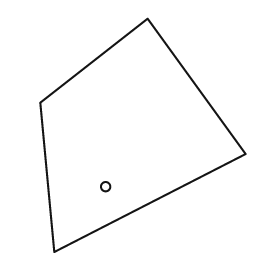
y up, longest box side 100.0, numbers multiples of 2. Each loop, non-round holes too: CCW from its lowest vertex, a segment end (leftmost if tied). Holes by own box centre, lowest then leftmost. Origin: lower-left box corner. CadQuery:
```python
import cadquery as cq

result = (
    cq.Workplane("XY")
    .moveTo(6.0, 0.0)
    .lineTo(88.0, 42.0)
    .lineTo(46.0, 100.0)
    .lineTo(0.0, 64.0)
    .close()
    .moveTo(28.0, 28.0)
    .circle(2.0)
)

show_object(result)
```